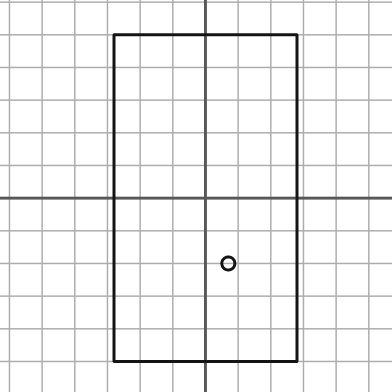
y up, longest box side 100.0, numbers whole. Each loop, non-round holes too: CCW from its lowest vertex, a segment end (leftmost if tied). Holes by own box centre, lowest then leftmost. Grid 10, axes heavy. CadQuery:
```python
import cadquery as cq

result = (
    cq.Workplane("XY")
    .moveTo(-28.0, -50.0)
    .lineTo(28.0, -50.0)
    .lineTo(28.0, 50.0)
    .lineTo(-28.0, 50.0)
    .close()
    .moveTo(7.0, -20.0)
    .circle(2.0)
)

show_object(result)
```